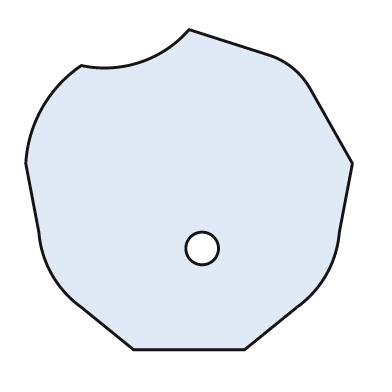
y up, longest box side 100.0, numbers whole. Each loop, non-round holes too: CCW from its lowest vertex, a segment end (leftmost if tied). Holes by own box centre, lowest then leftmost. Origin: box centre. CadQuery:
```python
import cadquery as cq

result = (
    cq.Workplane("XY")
    .moveTo(-17.0, -49.0)
    .lineTo(17.0, -49.0)
    .lineTo(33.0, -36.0)
    .threePointArc((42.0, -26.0), (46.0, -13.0))
    .lineTo(50.0, 8.0)
    .lineTo(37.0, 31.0)
    .threePointArc((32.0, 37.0), (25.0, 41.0))
    .lineTo(0.0, 49.0)
    .threePointArc((-15.0, 39.0), (-33.0, 38.0))
    .threePointArc((-45.0, 25.0), (-50.0, 8.0))
    .lineTo(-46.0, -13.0)
    .threePointArc((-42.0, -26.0), (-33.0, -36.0))
    .close()
    .moveTo(4.0, -18.0)
    .circle(5.0)
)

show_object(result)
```